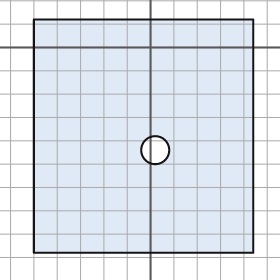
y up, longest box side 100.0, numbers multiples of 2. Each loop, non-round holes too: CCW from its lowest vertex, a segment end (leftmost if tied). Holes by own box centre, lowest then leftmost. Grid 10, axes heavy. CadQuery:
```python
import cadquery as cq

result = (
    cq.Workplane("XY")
    .moveTo(-50.0, -88.0)
    .lineTo(44.0, -88.0)
    .lineTo(44.0, 12.0)
    .lineTo(-50.0, 12.0)
    .close()
    .moveTo(2.0, -44.0)
    .circle(6.0)
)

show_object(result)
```